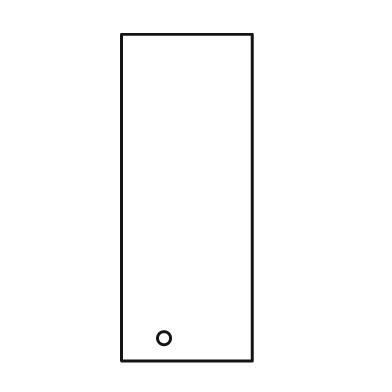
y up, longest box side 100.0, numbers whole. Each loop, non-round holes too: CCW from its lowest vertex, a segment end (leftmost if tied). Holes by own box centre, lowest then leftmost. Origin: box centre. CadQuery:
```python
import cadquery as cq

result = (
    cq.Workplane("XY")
    .moveTo(-20.0, -50.0)
    .lineTo(20.0, -50.0)
    .lineTo(20.0, 50.0)
    .lineTo(-20.0, 50.0)
    .close()
    .moveTo(-7.0, -43.0)
    .circle(2.0)
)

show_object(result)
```